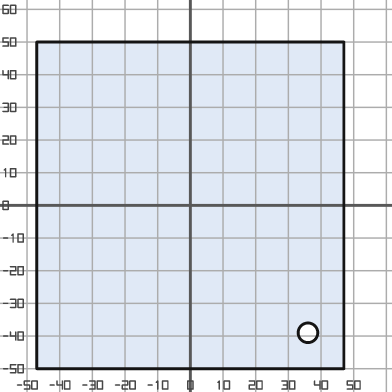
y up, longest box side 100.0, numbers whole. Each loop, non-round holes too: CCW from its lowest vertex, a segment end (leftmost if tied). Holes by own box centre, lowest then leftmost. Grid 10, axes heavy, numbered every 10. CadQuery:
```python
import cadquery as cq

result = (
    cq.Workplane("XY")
    .moveTo(-47.0, -50.0)
    .lineTo(47.0, -50.0)
    .lineTo(47.0, 50.0)
    .lineTo(-47.0, 50.0)
    .close()
    .moveTo(36.0, -39.0)
    .circle(3.0)
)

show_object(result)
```